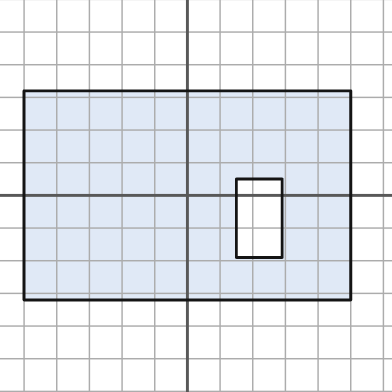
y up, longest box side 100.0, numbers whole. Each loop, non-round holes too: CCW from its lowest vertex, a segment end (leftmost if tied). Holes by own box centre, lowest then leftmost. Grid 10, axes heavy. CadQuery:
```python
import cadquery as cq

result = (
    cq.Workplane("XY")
    .moveTo(-50.0, -32.0)
    .lineTo(50.0, -32.0)
    .lineTo(50.0, 32.0)
    .lineTo(-50.0, 32.0)
    .close()
    .moveTo(15.0, -19.0)
    .lineTo(29.0, -19.0)
    .lineTo(29.0, 5.0)
    .lineTo(15.0, 5.0)
    .close()
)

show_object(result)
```